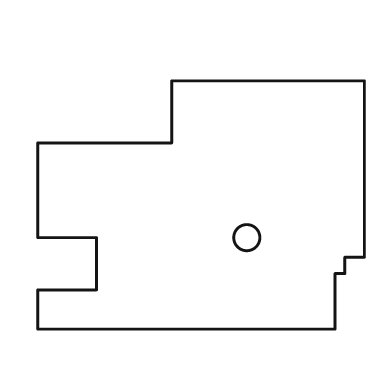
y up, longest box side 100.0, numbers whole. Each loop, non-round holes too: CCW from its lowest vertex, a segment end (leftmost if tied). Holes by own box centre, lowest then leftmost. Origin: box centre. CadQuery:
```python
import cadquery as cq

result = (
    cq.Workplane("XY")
    .moveTo(-50.0, -38.0)
    .lineTo(41.0, -38.0)
    .lineTo(41.0, -21.0)
    .lineTo(44.0, -21.0)
    .lineTo(44.0, -16.0)
    .lineTo(50.0, -16.0)
    .lineTo(50.0, 38.0)
    .lineTo(-9.0, 38.0)
    .lineTo(-9.0, 19.0)
    .lineTo(-50.0, 19.0)
    .lineTo(-50.0, -10.0)
    .lineTo(-32.0, -10.0)
    .lineTo(-32.0, -26.0)
    .lineTo(-50.0, -26.0)
    .close()
    .moveTo(14.0, -10.0)
    .circle(4.0)
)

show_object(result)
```